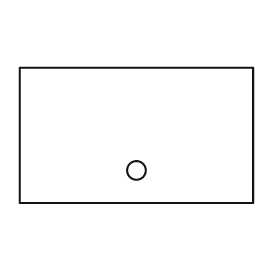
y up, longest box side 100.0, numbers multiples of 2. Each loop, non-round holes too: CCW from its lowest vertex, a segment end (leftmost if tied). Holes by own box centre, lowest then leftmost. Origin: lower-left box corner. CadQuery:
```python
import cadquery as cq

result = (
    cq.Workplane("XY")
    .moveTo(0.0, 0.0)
    .lineTo(100.0, 0.0)
    .lineTo(100.0, 58.0)
    .lineTo(0.0, 58.0)
    .close()
    .moveTo(50.0, 14.0)
    .circle(4.0)
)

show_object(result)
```